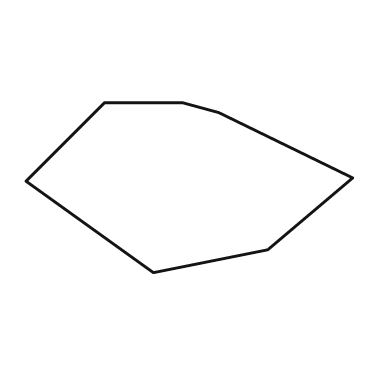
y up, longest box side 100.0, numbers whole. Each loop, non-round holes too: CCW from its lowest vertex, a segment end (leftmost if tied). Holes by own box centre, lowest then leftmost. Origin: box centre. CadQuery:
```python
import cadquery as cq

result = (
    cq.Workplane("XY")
    .moveTo(-11.0, -26.0)
    .lineTo(24.0, -19.0)
    .lineTo(50.0, 3.0)
    .lineTo(9.0, 23.0)
    .lineTo(-2.0, 26.0)
    .lineTo(-26.0, 26.0)
    .lineTo(-50.0, 2.0)
    .close()
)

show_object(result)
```